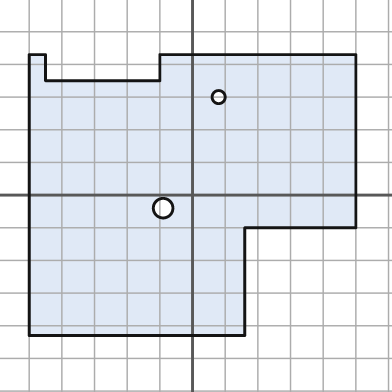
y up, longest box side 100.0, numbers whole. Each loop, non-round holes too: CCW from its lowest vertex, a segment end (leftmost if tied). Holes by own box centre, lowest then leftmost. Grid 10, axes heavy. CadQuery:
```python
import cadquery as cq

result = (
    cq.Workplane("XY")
    .moveTo(-50.0, -43.0)
    .lineTo(16.0, -43.0)
    .lineTo(16.0, -10.0)
    .lineTo(50.0, -10.0)
    .lineTo(50.0, 43.0)
    .lineTo(-10.0, 43.0)
    .lineTo(-10.0, 35.0)
    .lineTo(-45.0, 35.0)
    .lineTo(-45.0, 43.0)
    .lineTo(-50.0, 43.0)
    .close()
    .moveTo(-9.0, -4.0)
    .circle(3.0)
    .moveTo(8.0, 30.0)
    .circle(2.0)
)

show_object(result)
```